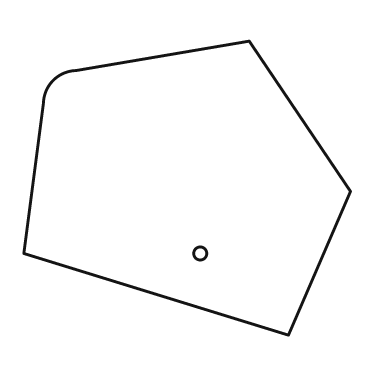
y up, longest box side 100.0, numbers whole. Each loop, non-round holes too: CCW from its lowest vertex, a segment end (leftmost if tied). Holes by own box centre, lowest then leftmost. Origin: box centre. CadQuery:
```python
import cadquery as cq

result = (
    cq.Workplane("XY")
    .moveTo(31.0, -45.0)
    .lineTo(50.0, -1.0)
    .lineTo(19.0, 45.0)
    .lineTo(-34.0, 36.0)
    .threePointArc((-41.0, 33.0), (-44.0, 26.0))
    .lineTo(-50.0, -20.0)
    .close()
    .moveTo(4.0, -20.0)
    .circle(2.0)
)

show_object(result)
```